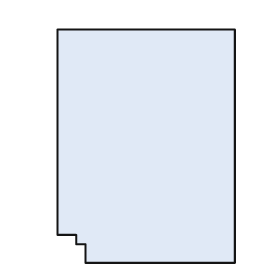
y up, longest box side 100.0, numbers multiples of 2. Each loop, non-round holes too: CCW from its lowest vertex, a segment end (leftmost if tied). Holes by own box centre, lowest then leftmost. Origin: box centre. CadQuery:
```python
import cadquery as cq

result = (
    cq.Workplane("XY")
    .moveTo(-26.0, -50.0)
    .lineTo(38.0, -50.0)
    .lineTo(38.0, 50.0)
    .lineTo(-38.0, 50.0)
    .lineTo(-38.0, -38.0)
    .lineTo(-30.0, -38.0)
    .lineTo(-30.0, -42.0)
    .lineTo(-26.0, -42.0)
    .close()
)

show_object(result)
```